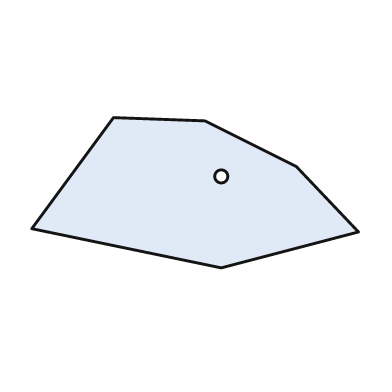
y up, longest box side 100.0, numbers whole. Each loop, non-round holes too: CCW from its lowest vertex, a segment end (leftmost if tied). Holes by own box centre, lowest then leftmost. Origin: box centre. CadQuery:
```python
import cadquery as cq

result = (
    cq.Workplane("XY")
    .moveTo(8.0, -23.0)
    .lineTo(50.0, -12.0)
    .lineTo(31.0, 8.0)
    .lineTo(3.0, 22.0)
    .lineTo(-25.0, 23.0)
    .lineTo(-50.0, -11.0)
    .close()
    .moveTo(8.0, 5.0)
    .circle(2.0)
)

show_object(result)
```